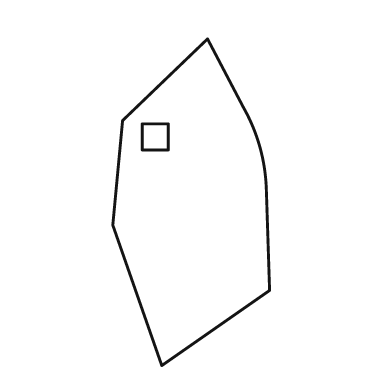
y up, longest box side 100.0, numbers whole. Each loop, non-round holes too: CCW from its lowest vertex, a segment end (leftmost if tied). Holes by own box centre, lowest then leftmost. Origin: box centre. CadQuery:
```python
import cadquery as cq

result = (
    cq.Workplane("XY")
    .moveTo(-9.0, -50.0)
    .lineTo(24.0, -27.0)
    .lineTo(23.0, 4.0)
    .threePointArc((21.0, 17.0), (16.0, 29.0))
    .lineTo(5.0, 50.0)
    .lineTo(-21.0, 25.0)
    .lineTo(-24.0, -7.0)
    .close()
    .moveTo(-15.0, 16.0)
    .lineTo(-7.0, 16.0)
    .lineTo(-7.0, 24.0)
    .lineTo(-15.0, 24.0)
    .close()
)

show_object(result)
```